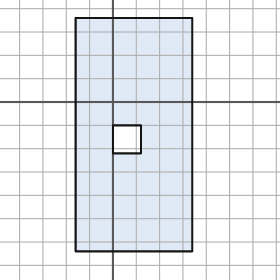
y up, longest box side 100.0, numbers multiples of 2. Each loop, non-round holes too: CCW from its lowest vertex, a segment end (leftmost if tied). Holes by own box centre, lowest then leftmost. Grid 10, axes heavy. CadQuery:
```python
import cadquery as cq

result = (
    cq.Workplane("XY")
    .moveTo(-16.0, -64.0)
    .lineTo(34.0, -64.0)
    .lineTo(34.0, 36.0)
    .lineTo(-16.0, 36.0)
    .close()
    .moveTo(0.0, -22.0)
    .lineTo(12.0, -22.0)
    .lineTo(12.0, -10.0)
    .lineTo(0.0, -10.0)
    .close()
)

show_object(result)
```